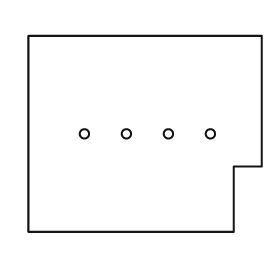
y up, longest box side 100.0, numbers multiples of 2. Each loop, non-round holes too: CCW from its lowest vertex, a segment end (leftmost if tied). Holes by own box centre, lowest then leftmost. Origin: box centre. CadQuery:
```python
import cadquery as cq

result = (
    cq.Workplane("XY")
    .moveTo(-50.0, -42.0)
    .lineTo(38.0, -42.0)
    .lineTo(38.0, -14.0)
    .lineTo(50.0, -14.0)
    .lineTo(50.0, 42.0)
    .lineTo(-50.0, 42.0)
    .close()
    .moveTo(-26.0, 0.0)
    .circle(2.0)
    .moveTo(-8.0, 0.0)
    .circle(2.0)
    .moveTo(10.0, 0.0)
    .circle(2.0)
    .moveTo(28.0, 0.0)
    .circle(2.0)
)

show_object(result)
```